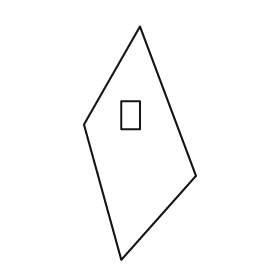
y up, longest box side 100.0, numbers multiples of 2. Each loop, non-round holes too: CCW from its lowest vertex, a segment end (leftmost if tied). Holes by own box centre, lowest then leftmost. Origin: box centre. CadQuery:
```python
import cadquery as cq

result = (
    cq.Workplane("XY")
    .moveTo(-8.0, -50.0)
    .lineTo(24.0, -14.0)
    .lineTo(0.0, 50.0)
    .lineTo(-24.0, 8.0)
    .close()
    .moveTo(-8.0, 6.0)
    .lineTo(0.0, 6.0)
    .lineTo(0.0, 18.0)
    .lineTo(-8.0, 18.0)
    .close()
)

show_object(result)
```